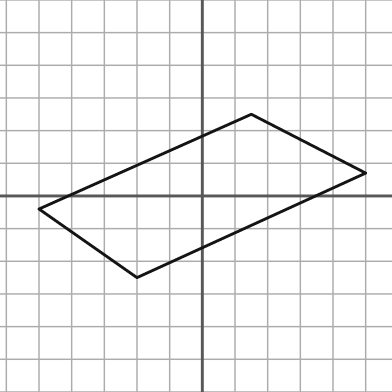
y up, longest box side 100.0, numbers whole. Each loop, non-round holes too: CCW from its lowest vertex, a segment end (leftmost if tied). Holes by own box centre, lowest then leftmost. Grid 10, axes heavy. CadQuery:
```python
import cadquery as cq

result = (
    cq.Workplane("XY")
    .moveTo(-20.0, -25.0)
    .lineTo(50.0, 7.0)
    .lineTo(15.0, 25.0)
    .lineTo(-50.0, -4.0)
    .close()
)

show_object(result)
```